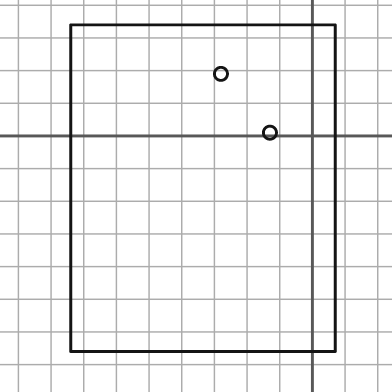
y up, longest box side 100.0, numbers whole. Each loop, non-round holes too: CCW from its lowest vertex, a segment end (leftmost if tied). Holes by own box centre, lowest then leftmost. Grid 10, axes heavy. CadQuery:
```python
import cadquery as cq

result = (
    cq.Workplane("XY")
    .moveTo(-74.0, -66.0)
    .lineTo(7.0, -66.0)
    .lineTo(7.0, 34.0)
    .lineTo(-74.0, 34.0)
    .close()
    .moveTo(-13.0, 1.0)
    .circle(2.0)
    .moveTo(-28.0, 19.0)
    .circle(2.0)
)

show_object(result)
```